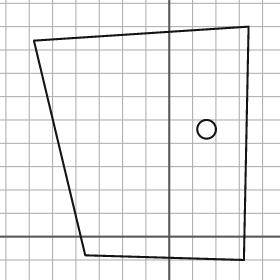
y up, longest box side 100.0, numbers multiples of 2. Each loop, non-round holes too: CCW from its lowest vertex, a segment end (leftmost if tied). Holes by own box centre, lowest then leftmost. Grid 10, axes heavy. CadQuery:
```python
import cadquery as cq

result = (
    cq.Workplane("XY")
    .moveTo(32.0, -10.0)
    .lineTo(34.0, 90.0)
    .lineTo(-58.0, 84.0)
    .lineTo(-36.0, -8.0)
    .close()
    .moveTo(16.0, 46.0)
    .circle(4.0)
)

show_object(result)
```